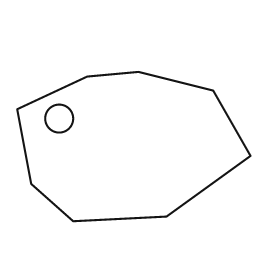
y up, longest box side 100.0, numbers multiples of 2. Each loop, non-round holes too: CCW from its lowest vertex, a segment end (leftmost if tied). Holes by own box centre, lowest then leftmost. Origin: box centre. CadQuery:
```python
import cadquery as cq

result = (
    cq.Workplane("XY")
    .moveTo(-26.0, -32.0)
    .lineTo(14.0, -30.0)
    .lineTo(50.0, -4.0)
    .lineTo(34.0, 24.0)
    .lineTo(2.0, 32.0)
    .lineTo(-20.0, 30.0)
    .lineTo(-50.0, 16.0)
    .lineTo(-44.0, -16.0)
    .close()
    .moveTo(-32.0, 12.0)
    .circle(6.0)
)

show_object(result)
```